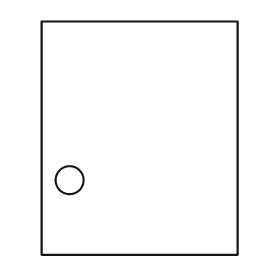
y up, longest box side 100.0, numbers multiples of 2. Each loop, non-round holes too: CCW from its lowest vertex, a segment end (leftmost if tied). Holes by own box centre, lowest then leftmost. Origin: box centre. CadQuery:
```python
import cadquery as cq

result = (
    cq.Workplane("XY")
    .moveTo(-42.0, -50.0)
    .lineTo(42.0, -50.0)
    .lineTo(42.0, 50.0)
    .lineTo(-42.0, 50.0)
    .close()
    .moveTo(-30.0, -18.0)
    .circle(6.0)
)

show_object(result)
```